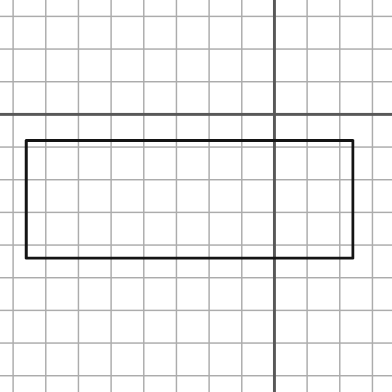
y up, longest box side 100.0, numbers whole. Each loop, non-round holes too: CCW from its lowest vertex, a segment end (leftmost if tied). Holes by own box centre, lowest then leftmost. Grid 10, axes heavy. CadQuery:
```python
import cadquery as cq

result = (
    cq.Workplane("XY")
    .moveTo(-76.0, -44.0)
    .lineTo(24.0, -44.0)
    .lineTo(24.0, -8.0)
    .lineTo(-76.0, -8.0)
    .close()
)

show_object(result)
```